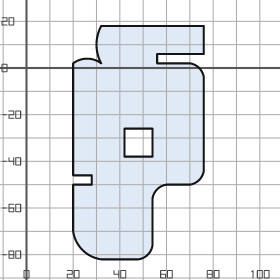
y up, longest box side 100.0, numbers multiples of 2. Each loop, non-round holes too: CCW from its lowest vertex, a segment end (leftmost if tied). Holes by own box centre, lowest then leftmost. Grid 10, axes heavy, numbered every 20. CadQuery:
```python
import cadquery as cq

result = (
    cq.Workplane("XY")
    .moveTo(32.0, -82.0)
    .lineTo(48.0, -82.0)
    .threePointArc((52.0, -80.0), (54.0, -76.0))
    .lineTo(54.0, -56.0)
    .threePointArc((56.0, -52.0), (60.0, -50.0))
    .lineTo(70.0, -50.0)
    .threePointArc((74.0, -48.0), (76.0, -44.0))
    .lineTo(76.0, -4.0)
    .threePointArc((74.0, 0.0), (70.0, 2.0))
    .lineTo(56.0, 2.0)
    .lineTo(56.0, 6.0)
    .lineTo(76.0, 6.0)
    .lineTo(76.0, 18.0)
    .lineTo(32.0, 18.0)
    .threePointArc((30.0, 10.0), (32.0, 2.0))
    .threePointArc((26.0, 4.0), (20.0, 2.0))
    .lineTo(20.0, -46.0)
    .lineTo(28.0, -46.0)
    .lineTo(28.0, -50.0)
    .lineTo(20.0, -50.0)
    .lineTo(20.0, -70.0)
    .threePointArc((24.0, -78.0), (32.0, -82.0))
    .close()
    .moveTo(42.0, -38.0)
    .lineTo(54.0, -38.0)
    .lineTo(54.0, -26.0)
    .lineTo(42.0, -26.0)
    .close()
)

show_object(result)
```